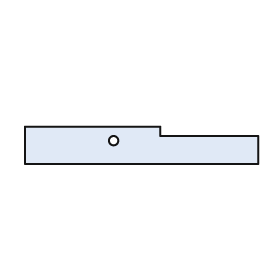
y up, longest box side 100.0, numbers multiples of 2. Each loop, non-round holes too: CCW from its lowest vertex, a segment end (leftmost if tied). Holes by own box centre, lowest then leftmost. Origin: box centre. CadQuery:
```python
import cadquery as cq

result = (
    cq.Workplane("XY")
    .moveTo(-50.0, -8.0)
    .lineTo(50.0, -8.0)
    .lineTo(50.0, 4.0)
    .lineTo(8.0, 4.0)
    .lineTo(8.0, 8.0)
    .lineTo(-50.0, 8.0)
    .close()
    .moveTo(-12.0, 2.0)
    .circle(2.0)
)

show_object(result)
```